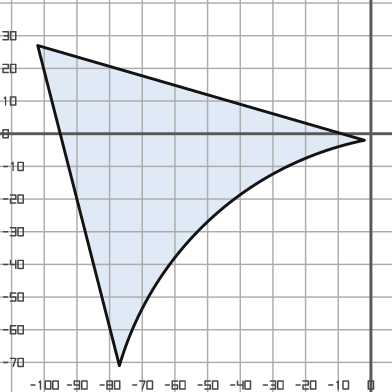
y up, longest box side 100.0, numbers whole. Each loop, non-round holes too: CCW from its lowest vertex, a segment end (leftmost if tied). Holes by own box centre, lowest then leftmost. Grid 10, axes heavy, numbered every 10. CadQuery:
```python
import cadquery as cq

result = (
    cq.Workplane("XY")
    .moveTo(-77.0, -71.0)
    .threePointArc((-49.0, -26.0), (-2.0, -2.0))
    .lineTo(-102.0, 27.0)
    .close()
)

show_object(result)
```